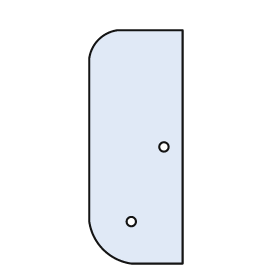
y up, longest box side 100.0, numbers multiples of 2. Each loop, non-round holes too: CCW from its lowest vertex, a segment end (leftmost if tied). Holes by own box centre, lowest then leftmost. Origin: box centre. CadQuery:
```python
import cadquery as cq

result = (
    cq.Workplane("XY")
    .moveTo(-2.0, -50.0)
    .lineTo(20.0, -50.0)
    .lineTo(20.0, 50.0)
    .lineTo(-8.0, 50.0)
    .threePointArc((-16.0, 46.0), (-20.0, 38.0))
    .lineTo(-20.0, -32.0)
    .threePointArc((-14.0, -44.0), (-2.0, -50.0))
    .close()
    .moveTo(-2.0, -32.0)
    .circle(2.0)
    .moveTo(12.0, 0.0)
    .circle(2.0)
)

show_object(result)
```